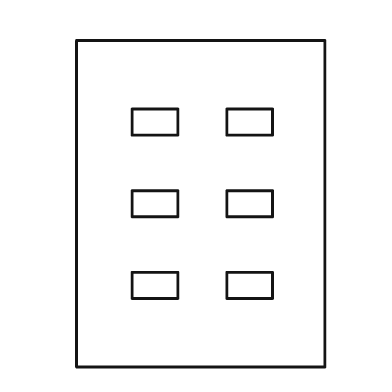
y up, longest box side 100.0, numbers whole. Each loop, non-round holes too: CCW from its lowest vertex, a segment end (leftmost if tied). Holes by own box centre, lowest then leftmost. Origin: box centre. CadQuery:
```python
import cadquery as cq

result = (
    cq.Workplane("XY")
    .moveTo(-38.0, -50.0)
    .lineTo(38.0, -50.0)
    .lineTo(38.0, 50.0)
    .lineTo(-38.0, 50.0)
    .close()
    .moveTo(-21.0, -29.0)
    .lineTo(-7.0, -29.0)
    .lineTo(-7.0, -21.0)
    .lineTo(-21.0, -21.0)
    .close()
    .moveTo(8.0, -29.0)
    .lineTo(22.0, -29.0)
    .lineTo(22.0, -21.0)
    .lineTo(8.0, -21.0)
    .close()
    .moveTo(-21.0, -4.0)
    .lineTo(-7.0, -4.0)
    .lineTo(-7.0, 4.0)
    .lineTo(-21.0, 4.0)
    .close()
    .moveTo(8.0, -4.0)
    .lineTo(22.0, -4.0)
    .lineTo(22.0, 4.0)
    .lineTo(8.0, 4.0)
    .close()
    .moveTo(-21.0, 21.0)
    .lineTo(-7.0, 21.0)
    .lineTo(-7.0, 29.0)
    .lineTo(-21.0, 29.0)
    .close()
    .moveTo(8.0, 21.0)
    .lineTo(22.0, 21.0)
    .lineTo(22.0, 29.0)
    .lineTo(8.0, 29.0)
    .close()
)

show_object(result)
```